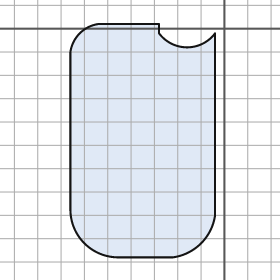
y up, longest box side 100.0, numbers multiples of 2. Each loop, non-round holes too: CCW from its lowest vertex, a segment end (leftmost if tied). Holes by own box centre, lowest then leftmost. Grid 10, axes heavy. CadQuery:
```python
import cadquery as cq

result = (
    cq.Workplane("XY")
    .moveTo(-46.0, -98.0)
    .lineTo(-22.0, -98.0)
    .threePointArc((-10.0, -92.0), (-4.0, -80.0))
    .lineTo(-4.0, -2.0)
    .threePointArc((-16.0, -8.0), (-28.0, -2.0))
    .lineTo(-28.0, 2.0)
    .lineTo(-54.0, 2.0)
    .threePointArc((-62.0, -2.0), (-66.0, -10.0))
    .lineTo(-66.0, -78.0)
    .threePointArc((-60.0, -92.0), (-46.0, -98.0))
    .close()
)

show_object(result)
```